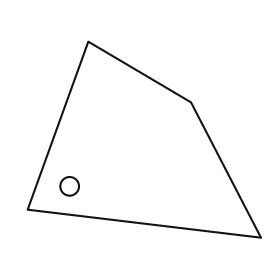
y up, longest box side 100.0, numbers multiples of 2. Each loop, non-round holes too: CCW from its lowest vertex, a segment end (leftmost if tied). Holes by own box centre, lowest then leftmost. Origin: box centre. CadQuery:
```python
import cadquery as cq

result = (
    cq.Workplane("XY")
    .moveTo(50.0, -42.0)
    .lineTo(20.0, 16.0)
    .lineTo(-24.0, 42.0)
    .lineTo(-50.0, -30.0)
    .close()
    .moveTo(-32.0, -20.0)
    .circle(4.0)
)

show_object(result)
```